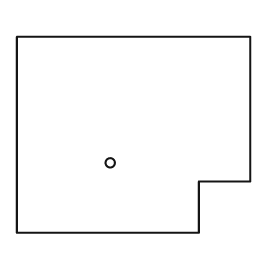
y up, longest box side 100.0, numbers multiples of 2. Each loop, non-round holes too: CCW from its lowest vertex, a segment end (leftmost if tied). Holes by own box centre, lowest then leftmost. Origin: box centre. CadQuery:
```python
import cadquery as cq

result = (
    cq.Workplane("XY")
    .moveTo(-50.0, -42.0)
    .lineTo(28.0, -42.0)
    .lineTo(28.0, -20.0)
    .lineTo(50.0, -20.0)
    .lineTo(50.0, 42.0)
    .lineTo(-50.0, 42.0)
    .close()
    .moveTo(-10.0, -12.0)
    .circle(2.0)
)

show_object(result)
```